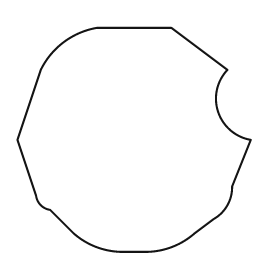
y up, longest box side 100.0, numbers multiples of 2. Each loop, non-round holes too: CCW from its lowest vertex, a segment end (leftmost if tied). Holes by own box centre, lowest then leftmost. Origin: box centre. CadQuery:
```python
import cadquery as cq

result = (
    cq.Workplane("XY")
    .moveTo(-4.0, -48.0)
    .lineTo(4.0, -48.0)
    .threePointArc((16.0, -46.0), (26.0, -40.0))
    .lineTo(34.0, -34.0)
    .threePointArc((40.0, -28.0), (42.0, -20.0))
    .lineTo(50.0, 0.0)
    .threePointArc((36.0, 12.0), (40.0, 30.0))
    .lineTo(16.0, 48.0)
    .lineTo(-16.0, 48.0)
    .threePointArc((-30.0, 42.0), (-40.0, 30.0))
    .lineTo(-50.0, 0.0)
    .lineTo(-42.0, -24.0)
    .threePointArc((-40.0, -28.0), (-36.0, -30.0))
    .lineTo(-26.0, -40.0)
    .threePointArc((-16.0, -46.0), (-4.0, -48.0))
    .close()
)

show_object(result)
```